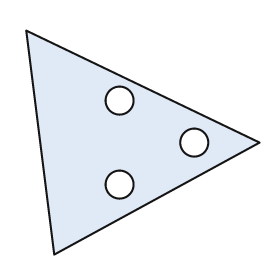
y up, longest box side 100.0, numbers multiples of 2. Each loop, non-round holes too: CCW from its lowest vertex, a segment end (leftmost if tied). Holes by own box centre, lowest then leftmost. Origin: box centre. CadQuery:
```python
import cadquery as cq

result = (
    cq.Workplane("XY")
    .moveTo(-38.0, -48.0)
    .lineTo(50.0, 0.0)
    .lineTo(-50.0, 48.0)
    .close()
    .moveTo(-10.0, -18.0)
    .circle(6.0)
    .moveTo(22.0, 0.0)
    .circle(6.0)
    .moveTo(-10.0, 18.0)
    .circle(6.0)
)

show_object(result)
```